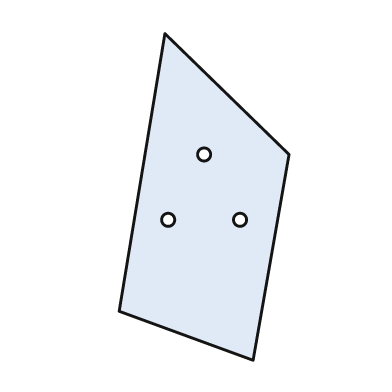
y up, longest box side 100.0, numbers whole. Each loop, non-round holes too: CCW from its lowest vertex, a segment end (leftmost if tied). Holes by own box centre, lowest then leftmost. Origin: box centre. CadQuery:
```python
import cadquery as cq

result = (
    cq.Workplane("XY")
    .moveTo(15.0, -50.0)
    .lineTo(26.0, 13.0)
    .lineTo(-12.0, 50.0)
    .lineTo(-26.0, -35.0)
    .close()
    .moveTo(-11.0, -7.0)
    .circle(2.0)
    .moveTo(11.0, -7.0)
    .circle(2.0)
    .moveTo(0.0, 13.0)
    .circle(2.0)
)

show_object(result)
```